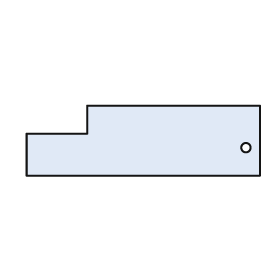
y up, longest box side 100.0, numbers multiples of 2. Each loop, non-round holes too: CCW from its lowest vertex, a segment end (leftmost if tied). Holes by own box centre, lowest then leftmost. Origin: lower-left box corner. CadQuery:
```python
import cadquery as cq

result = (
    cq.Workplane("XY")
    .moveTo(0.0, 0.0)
    .lineTo(100.0, 0.0)
    .lineTo(100.0, 30.0)
    .lineTo(26.0, 30.0)
    .lineTo(26.0, 18.0)
    .lineTo(0.0, 18.0)
    .close()
    .moveTo(94.0, 12.0)
    .circle(2.0)
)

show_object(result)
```